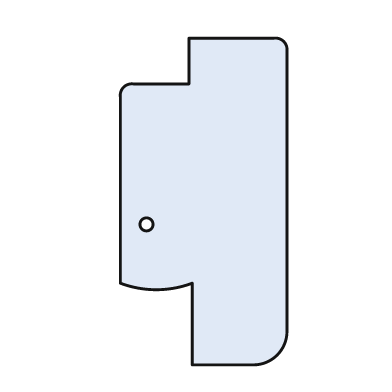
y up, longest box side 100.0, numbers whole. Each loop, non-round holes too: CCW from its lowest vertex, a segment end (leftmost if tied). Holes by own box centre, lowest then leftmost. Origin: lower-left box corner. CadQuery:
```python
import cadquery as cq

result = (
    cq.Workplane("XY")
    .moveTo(22.0, 0.0)
    .lineTo(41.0, 0.0)
    .threePointArc((48.0, 3.0), (51.0, 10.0))
    .lineTo(51.0, 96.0)
    .threePointArc((50.0, 99.0), (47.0, 100.0))
    .lineTo(21.0, 100.0)
    .lineTo(21.0, 86.0)
    .lineTo(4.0, 86.0)
    .threePointArc((1.0, 85.0), (0.0, 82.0))
    .lineTo(0.0, 25.0)
    .threePointArc((11.0, 23.0), (22.0, 25.0))
    .close()
    .moveTo(8.0, 43.0)
    .circle(2.0)
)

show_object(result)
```